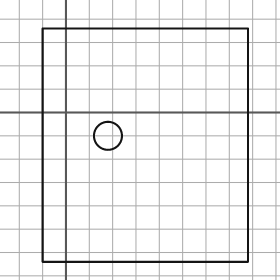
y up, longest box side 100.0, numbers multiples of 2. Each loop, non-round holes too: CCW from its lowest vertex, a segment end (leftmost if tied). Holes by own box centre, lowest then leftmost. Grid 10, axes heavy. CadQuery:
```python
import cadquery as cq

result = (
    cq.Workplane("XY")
    .moveTo(-10.0, -64.0)
    .lineTo(78.0, -64.0)
    .lineTo(78.0, 36.0)
    .lineTo(-10.0, 36.0)
    .close()
    .moveTo(18.0, -10.0)
    .circle(6.0)
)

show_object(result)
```